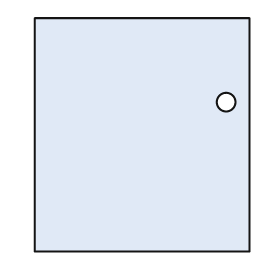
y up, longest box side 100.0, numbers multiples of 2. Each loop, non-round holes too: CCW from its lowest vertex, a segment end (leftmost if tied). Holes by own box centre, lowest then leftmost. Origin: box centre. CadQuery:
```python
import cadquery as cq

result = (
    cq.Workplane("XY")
    .moveTo(-46.0, -50.0)
    .lineTo(46.0, -50.0)
    .lineTo(46.0, 50.0)
    .lineTo(-46.0, 50.0)
    .close()
    .moveTo(36.0, 14.0)
    .circle(4.0)
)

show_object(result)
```